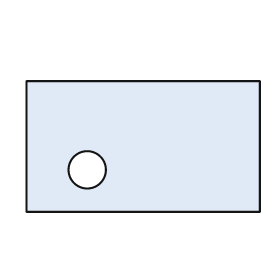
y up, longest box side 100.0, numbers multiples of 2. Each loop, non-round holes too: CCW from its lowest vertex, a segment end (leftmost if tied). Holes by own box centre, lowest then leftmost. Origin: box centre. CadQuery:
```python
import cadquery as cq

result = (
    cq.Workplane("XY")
    .moveTo(-50.0, -28.0)
    .lineTo(50.0, -28.0)
    .lineTo(50.0, 28.0)
    .lineTo(-50.0, 28.0)
    .close()
    .moveTo(-24.0, -10.0)
    .circle(8.0)
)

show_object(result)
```